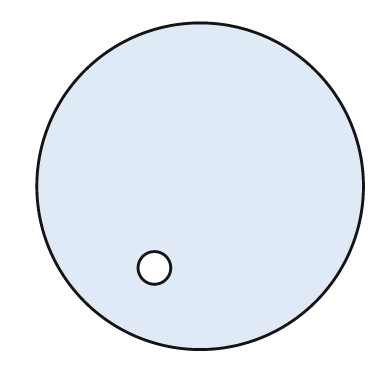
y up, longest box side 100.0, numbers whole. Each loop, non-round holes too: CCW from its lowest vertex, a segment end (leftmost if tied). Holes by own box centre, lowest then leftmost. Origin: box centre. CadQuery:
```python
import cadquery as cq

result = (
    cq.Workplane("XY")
    .moveTo(0.0, 0.0)
    .circle(50.0)
    .moveTo(-14.0, -25.0)
    .circle(5.0)
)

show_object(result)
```